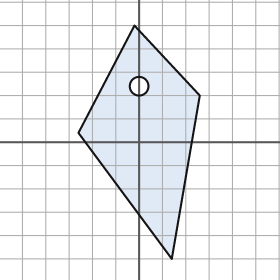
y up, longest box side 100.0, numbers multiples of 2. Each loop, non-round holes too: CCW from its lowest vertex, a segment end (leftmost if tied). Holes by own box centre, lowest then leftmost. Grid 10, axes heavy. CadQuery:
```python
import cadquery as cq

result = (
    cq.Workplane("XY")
    .moveTo(14.0, -50.0)
    .lineTo(26.0, 20.0)
    .lineTo(-2.0, 50.0)
    .lineTo(-26.0, 4.0)
    .close()
    .moveTo(0.0, 24.0)
    .circle(4.0)
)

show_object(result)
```